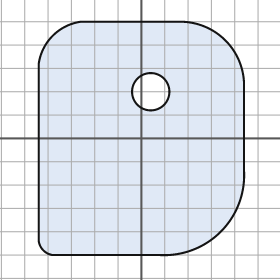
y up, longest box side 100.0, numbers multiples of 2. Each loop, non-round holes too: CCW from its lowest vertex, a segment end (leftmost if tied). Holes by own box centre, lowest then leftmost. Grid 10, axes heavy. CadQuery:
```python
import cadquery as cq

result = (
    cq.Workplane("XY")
    .moveTo(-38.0, -50.0)
    .lineTo(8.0, -50.0)
    .threePointArc((34.0, -40.0), (44.0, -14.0))
    .lineTo(44.0, 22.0)
    .threePointArc((36.0, 42.0), (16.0, 50.0))
    .lineTo(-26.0, 50.0)
    .threePointArc((-38.0, 44.0), (-44.0, 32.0))
    .lineTo(-44.0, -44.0)
    .threePointArc((-42.0, -48.0), (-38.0, -50.0))
    .close()
    .moveTo(4.0, 20.0)
    .circle(8.0)
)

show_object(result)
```